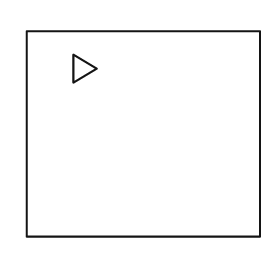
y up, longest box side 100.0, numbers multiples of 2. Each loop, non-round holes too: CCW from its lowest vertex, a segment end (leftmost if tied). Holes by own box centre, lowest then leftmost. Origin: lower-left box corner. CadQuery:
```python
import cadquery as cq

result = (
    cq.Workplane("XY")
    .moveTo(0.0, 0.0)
    .lineTo(100.0, 0.0)
    .lineTo(100.0, 88.0)
    .lineTo(0.0, 88.0)
    .close()
    .moveTo(20.0, 66.0)
    .lineTo(30.0, 72.0)
    .lineTo(20.0, 78.0)
    .close()
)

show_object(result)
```